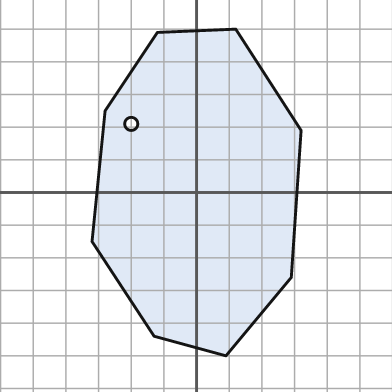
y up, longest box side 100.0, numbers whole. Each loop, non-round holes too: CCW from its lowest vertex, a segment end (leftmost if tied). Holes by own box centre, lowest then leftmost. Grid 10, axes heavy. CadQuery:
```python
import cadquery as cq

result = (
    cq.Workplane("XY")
    .moveTo(9.0, -50.0)
    .lineTo(29.0, -26.0)
    .lineTo(32.0, 19.0)
    .lineTo(12.0, 50.0)
    .lineTo(-12.0, 49.0)
    .lineTo(-28.0, 25.0)
    .lineTo(-32.0, -15.0)
    .lineTo(-13.0, -44.0)
    .close()
    .moveTo(-20.0, 21.0)
    .circle(2.0)
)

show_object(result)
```